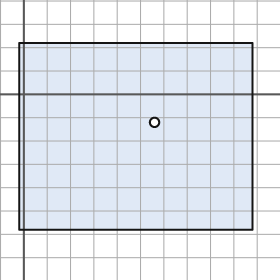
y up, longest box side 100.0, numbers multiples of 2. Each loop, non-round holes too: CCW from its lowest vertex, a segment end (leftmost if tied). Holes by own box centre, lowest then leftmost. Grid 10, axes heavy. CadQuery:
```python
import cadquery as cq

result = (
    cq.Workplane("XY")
    .moveTo(-2.0, -58.0)
    .lineTo(98.0, -58.0)
    .lineTo(98.0, 22.0)
    .lineTo(-2.0, 22.0)
    .close()
    .moveTo(56.0, -12.0)
    .circle(2.0)
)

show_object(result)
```